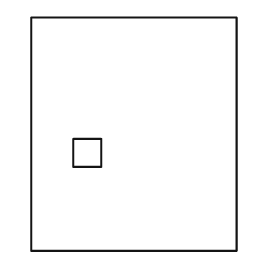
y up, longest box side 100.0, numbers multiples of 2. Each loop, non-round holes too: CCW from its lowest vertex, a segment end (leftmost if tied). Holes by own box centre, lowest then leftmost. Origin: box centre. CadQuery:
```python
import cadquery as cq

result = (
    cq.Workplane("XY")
    .moveTo(-44.0, -50.0)
    .lineTo(44.0, -50.0)
    .lineTo(44.0, 50.0)
    .lineTo(-44.0, 50.0)
    .close()
    .moveTo(-26.0, -14.0)
    .lineTo(-14.0, -14.0)
    .lineTo(-14.0, -2.0)
    .lineTo(-26.0, -2.0)
    .close()
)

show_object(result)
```